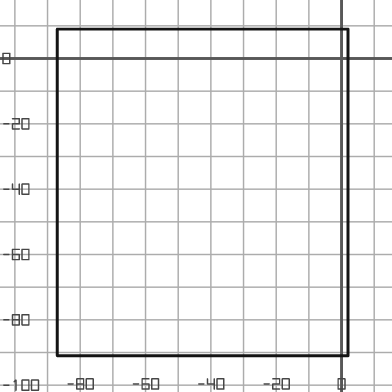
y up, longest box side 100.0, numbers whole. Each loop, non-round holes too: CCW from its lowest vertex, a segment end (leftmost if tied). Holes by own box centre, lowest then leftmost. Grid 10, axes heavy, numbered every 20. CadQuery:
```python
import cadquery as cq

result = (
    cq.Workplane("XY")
    .moveTo(-87.0, -91.0)
    .lineTo(2.0, -91.0)
    .lineTo(2.0, 9.0)
    .lineTo(-87.0, 9.0)
    .close()
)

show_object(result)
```